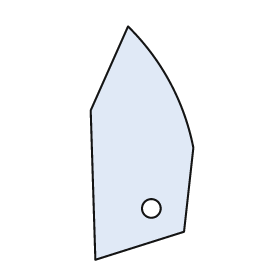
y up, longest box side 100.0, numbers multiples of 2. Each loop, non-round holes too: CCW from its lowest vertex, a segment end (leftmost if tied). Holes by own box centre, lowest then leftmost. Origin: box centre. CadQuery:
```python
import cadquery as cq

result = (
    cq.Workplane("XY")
    .moveTo(-20.0, -50.0)
    .lineTo(18.0, -38.0)
    .lineTo(22.0, -2.0)
    .threePointArc((12.0, 26.0), (-6.0, 50.0))
    .lineTo(-22.0, 14.0)
    .close()
    .moveTo(4.0, -28.0)
    .circle(4.0)
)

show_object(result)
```